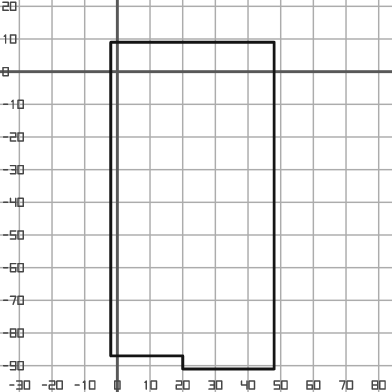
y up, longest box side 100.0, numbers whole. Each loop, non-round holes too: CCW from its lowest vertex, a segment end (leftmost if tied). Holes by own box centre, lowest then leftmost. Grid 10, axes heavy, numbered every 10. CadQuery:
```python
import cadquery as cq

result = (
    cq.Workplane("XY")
    .moveTo(20.0, -91.0)
    .lineTo(48.0, -91.0)
    .lineTo(48.0, 9.0)
    .lineTo(-2.0, 9.0)
    .lineTo(-2.0, -87.0)
    .lineTo(20.0, -87.0)
    .close()
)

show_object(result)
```